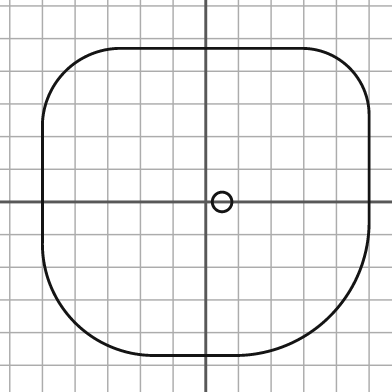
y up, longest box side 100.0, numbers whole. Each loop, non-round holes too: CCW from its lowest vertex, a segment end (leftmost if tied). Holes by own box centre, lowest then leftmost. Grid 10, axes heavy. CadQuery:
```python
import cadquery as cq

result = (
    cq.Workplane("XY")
    .moveTo(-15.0, -47.0)
    .lineTo(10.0, -47.0)
    .threePointArc((38.0, -35.0), (50.0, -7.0))
    .lineTo(50.0, 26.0)
    .threePointArc((44.0, 41.0), (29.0, 47.0))
    .lineTo(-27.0, 47.0)
    .threePointArc((-43.0, 40.0), (-50.0, 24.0))
    .lineTo(-50.0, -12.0)
    .threePointArc((-40.0, -37.0), (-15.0, -47.0))
    .close()
    .moveTo(5.0, 0.0)
    .circle(3.0)
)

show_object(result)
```